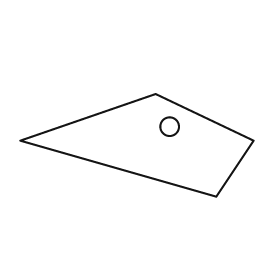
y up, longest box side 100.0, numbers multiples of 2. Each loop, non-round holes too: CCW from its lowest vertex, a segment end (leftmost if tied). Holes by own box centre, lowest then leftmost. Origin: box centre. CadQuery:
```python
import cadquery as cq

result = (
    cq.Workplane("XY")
    .moveTo(34.0, -22.0)
    .lineTo(50.0, 2.0)
    .lineTo(8.0, 22.0)
    .lineTo(-50.0, 2.0)
    .close()
    .moveTo(14.0, 8.0)
    .circle(4.0)
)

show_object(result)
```